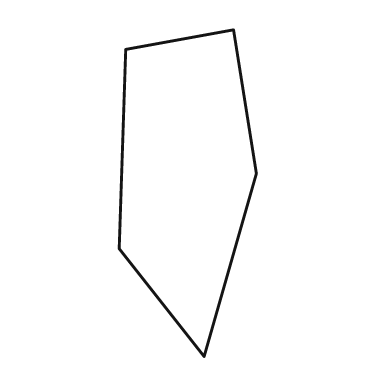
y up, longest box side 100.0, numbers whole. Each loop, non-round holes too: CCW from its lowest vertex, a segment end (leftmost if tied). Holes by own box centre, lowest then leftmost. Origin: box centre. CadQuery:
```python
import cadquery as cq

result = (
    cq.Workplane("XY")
    .moveTo(5.0, -50.0)
    .lineTo(21.0, 6.0)
    .lineTo(14.0, 50.0)
    .lineTo(-19.0, 44.0)
    .lineTo(-21.0, -17.0)
    .close()
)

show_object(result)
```